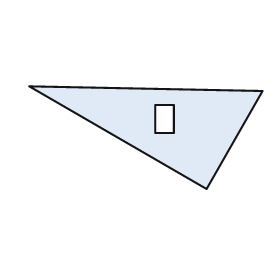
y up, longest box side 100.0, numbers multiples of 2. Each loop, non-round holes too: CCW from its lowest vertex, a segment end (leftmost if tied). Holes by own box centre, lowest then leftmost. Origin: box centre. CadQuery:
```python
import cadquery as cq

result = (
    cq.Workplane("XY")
    .moveTo(26.0, -22.0)
    .lineTo(50.0, 20.0)
    .lineTo(-50.0, 22.0)
    .close()
    .moveTo(4.0, 2.0)
    .lineTo(12.0, 2.0)
    .lineTo(12.0, 14.0)
    .lineTo(4.0, 14.0)
    .close()
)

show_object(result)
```